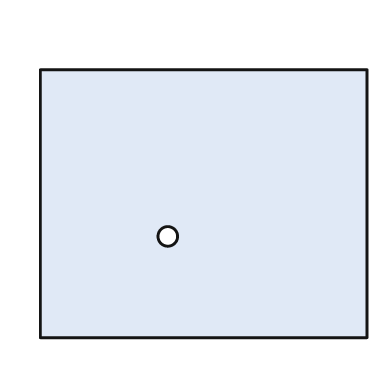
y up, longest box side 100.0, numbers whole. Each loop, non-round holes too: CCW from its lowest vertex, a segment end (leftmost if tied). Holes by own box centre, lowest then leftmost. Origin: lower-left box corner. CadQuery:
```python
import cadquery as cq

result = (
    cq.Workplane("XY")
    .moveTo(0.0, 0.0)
    .lineTo(100.0, 0.0)
    .lineTo(100.0, 82.0)
    .lineTo(0.0, 82.0)
    .close()
    .moveTo(39.0, 31.0)
    .circle(3.0)
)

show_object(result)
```